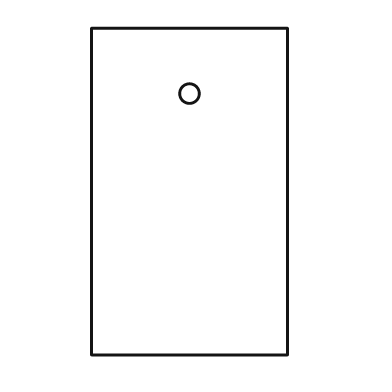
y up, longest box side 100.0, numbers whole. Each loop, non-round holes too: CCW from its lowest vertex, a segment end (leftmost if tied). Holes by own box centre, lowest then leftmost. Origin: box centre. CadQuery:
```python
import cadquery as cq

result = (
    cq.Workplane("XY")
    .moveTo(-30.0, -50.0)
    .lineTo(30.0, -50.0)
    .lineTo(30.0, 50.0)
    .lineTo(-30.0, 50.0)
    .close()
    .moveTo(0.0, 30.0)
    .circle(3.0)
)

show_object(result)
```